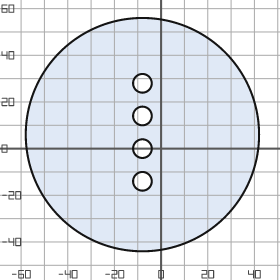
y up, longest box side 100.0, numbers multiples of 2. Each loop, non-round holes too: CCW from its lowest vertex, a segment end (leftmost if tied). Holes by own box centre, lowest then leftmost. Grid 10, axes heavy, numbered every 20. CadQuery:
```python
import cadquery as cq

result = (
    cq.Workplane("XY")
    .moveTo(-8.0, 6.0)
    .circle(50.0)
    .moveTo(-8.0, -14.0)
    .circle(4.0)
    .moveTo(-8.0, 0.0)
    .circle(4.0)
    .moveTo(-8.0, 14.0)
    .circle(4.0)
    .moveTo(-8.0, 28.0)
    .circle(4.0)
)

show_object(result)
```